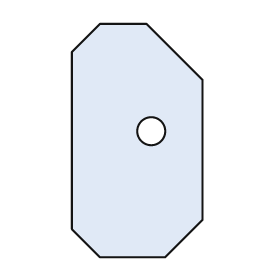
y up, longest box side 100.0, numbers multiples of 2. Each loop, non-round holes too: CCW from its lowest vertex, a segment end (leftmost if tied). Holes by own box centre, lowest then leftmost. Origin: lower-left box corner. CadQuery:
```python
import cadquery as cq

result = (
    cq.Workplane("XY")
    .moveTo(12.0, 0.0)
    .lineTo(40.0, 0.0)
    .lineTo(56.0, 16.0)
    .lineTo(56.0, 76.0)
    .lineTo(32.0, 100.0)
    .lineTo(12.0, 100.0)
    .lineTo(0.0, 88.0)
    .lineTo(0.0, 12.0)
    .close()
    .moveTo(34.0, 54.0)
    .circle(6.0)
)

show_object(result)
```